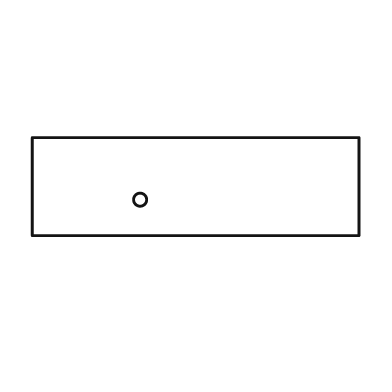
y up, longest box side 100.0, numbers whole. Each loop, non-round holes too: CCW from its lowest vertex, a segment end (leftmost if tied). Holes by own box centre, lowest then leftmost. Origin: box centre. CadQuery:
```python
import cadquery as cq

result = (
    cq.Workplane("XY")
    .moveTo(-50.0, -15.0)
    .lineTo(50.0, -15.0)
    .lineTo(50.0, 15.0)
    .lineTo(-50.0, 15.0)
    .close()
    .moveTo(-17.0, -4.0)
    .circle(2.0)
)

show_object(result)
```